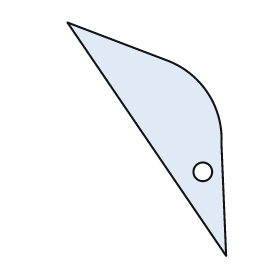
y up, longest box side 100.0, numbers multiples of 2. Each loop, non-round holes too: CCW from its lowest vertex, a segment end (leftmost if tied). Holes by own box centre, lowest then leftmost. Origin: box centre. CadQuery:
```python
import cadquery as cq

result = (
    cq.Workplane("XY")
    .moveTo(34.0, -50.0)
    .lineTo(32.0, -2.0)
    .threePointArc((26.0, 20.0), (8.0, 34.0))
    .lineTo(-34.0, 50.0)
    .close()
    .moveTo(24.0, -14.0)
    .circle(4.0)
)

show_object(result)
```